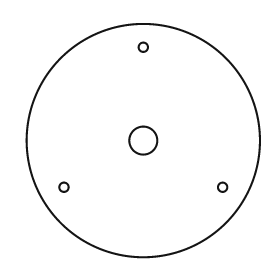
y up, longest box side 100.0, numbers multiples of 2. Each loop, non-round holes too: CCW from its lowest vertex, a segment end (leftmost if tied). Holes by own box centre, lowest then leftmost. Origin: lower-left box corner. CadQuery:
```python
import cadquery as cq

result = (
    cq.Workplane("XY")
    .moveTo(50.0, 50.0)
    .circle(50.0)
    .moveTo(16.0, 30.0)
    .circle(2.0)
    .moveTo(84.0, 30.0)
    .circle(2.0)
    .moveTo(50.0, 50.0)
    .circle(6.0)
    .moveTo(50.0, 90.0)
    .circle(2.0)
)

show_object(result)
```